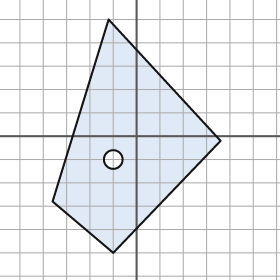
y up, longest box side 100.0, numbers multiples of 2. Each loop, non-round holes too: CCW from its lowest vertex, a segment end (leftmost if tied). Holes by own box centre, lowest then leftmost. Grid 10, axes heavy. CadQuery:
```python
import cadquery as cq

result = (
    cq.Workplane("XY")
    .moveTo(-10.0, -50.0)
    .lineTo(36.0, -2.0)
    .lineTo(-12.0, 50.0)
    .lineTo(-36.0, -28.0)
    .close()
    .moveTo(-10.0, -10.0)
    .circle(4.0)
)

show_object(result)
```